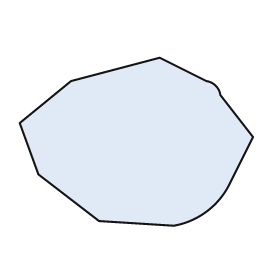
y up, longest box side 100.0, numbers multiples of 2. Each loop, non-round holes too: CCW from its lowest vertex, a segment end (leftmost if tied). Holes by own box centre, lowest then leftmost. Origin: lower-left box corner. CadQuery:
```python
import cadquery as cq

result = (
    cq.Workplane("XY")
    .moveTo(66.0, 0.0)
    .threePointArc((80.0, 6.0), (90.0, 18.0))
    .lineTo(100.0, 38.0)
    .lineTo(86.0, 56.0)
    .threePointArc((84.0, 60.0), (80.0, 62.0))
    .lineTo(60.0, 72.0)
    .lineTo(22.0, 62.0)
    .lineTo(0.0, 44.0)
    .lineTo(8.0, 22.0)
    .lineTo(34.0, 2.0)
    .close()
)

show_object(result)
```